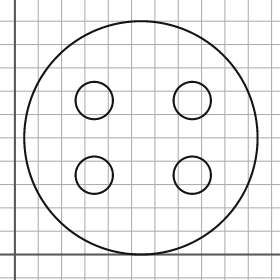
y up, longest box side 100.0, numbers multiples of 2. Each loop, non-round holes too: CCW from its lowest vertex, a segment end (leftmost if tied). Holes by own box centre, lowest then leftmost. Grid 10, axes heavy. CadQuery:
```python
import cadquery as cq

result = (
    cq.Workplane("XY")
    .moveTo(54.0, 50.0)
    .circle(50.0)
    .moveTo(34.0, 34.0)
    .circle(8.0)
    .moveTo(76.0, 34.0)
    .circle(8.0)
    .moveTo(34.0, 66.0)
    .circle(8.0)
    .moveTo(76.0, 66.0)
    .circle(8.0)
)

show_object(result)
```